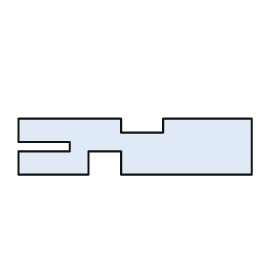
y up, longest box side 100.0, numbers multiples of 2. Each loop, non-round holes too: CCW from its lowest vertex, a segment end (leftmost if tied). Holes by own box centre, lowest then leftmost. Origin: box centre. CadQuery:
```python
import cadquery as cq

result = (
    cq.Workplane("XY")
    .moveTo(-50.0, -12.0)
    .lineTo(-20.0, -12.0)
    .lineTo(-20.0, -2.0)
    .lineTo(-6.0, -2.0)
    .lineTo(-6.0, -12.0)
    .lineTo(50.0, -12.0)
    .lineTo(50.0, 12.0)
    .lineTo(12.0, 12.0)
    .lineTo(12.0, 6.0)
    .lineTo(-6.0, 6.0)
    .lineTo(-6.0, 12.0)
    .lineTo(-50.0, 12.0)
    .lineTo(-50.0, 2.0)
    .lineTo(-28.0, 2.0)
    .lineTo(-28.0, -2.0)
    .lineTo(-50.0, -2.0)
    .close()
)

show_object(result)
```